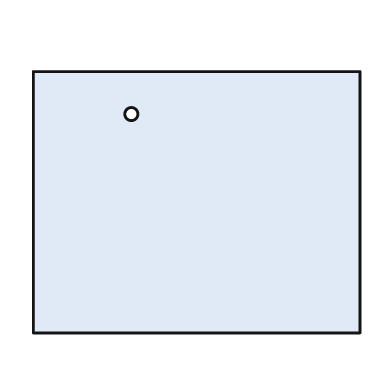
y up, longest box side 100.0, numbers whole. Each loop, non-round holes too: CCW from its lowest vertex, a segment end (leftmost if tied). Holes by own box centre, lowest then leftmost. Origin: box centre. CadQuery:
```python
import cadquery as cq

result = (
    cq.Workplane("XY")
    .moveTo(-50.0, -40.0)
    .lineTo(50.0, -40.0)
    .lineTo(50.0, 40.0)
    .lineTo(-50.0, 40.0)
    .close()
    .moveTo(-20.0, 27.0)
    .circle(2.0)
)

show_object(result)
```